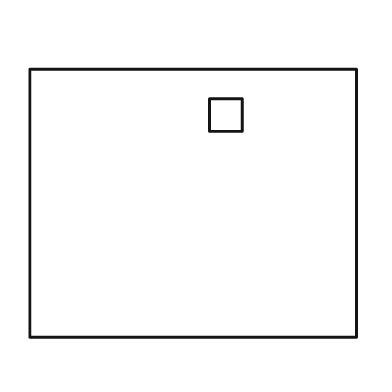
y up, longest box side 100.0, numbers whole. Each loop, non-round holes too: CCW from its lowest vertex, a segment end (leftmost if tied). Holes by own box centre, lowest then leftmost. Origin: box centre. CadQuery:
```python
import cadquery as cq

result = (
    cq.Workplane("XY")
    .moveTo(-50.0, -41.0)
    .lineTo(50.0, -41.0)
    .lineTo(50.0, 41.0)
    .lineTo(-50.0, 41.0)
    .close()
    .moveTo(5.0, 22.0)
    .lineTo(15.0, 22.0)
    .lineTo(15.0, 32.0)
    .lineTo(5.0, 32.0)
    .close()
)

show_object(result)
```